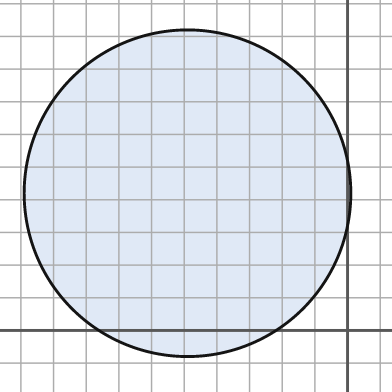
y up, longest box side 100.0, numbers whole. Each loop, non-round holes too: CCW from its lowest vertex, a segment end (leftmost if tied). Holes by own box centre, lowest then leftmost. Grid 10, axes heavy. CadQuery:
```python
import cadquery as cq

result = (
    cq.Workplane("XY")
    .moveTo(-49.0, 42.0)
    .circle(50.0)
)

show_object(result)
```